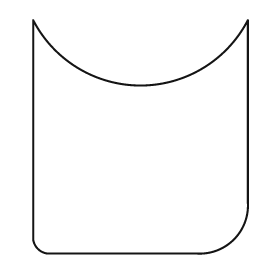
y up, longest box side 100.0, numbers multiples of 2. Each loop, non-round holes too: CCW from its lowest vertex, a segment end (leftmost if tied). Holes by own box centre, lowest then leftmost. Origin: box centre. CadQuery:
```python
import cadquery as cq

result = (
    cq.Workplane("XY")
    .moveTo(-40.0, -50.0)
    .lineTo(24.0, -50.0)
    .threePointArc((40.0, -44.0), (46.0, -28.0))
    .lineTo(46.0, 50.0)
    .threePointArc((0.0, 22.0), (-46.0, 50.0))
    .lineTo(-46.0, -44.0)
    .threePointArc((-44.0, -48.0), (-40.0, -50.0))
    .close()
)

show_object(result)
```